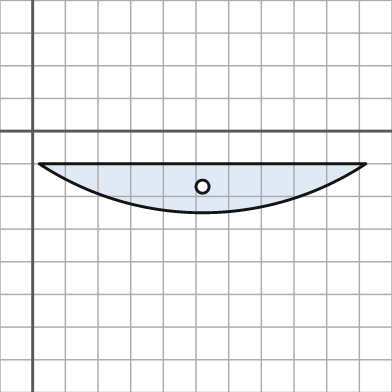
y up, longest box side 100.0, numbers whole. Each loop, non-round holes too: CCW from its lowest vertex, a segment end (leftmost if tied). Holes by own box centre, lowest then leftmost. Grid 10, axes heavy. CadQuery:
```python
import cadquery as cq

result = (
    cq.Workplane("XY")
    .moveTo(2.0, -10.0)
    .threePointArc((52.0, -25.0), (102.0, -10.0))
    .close()
    .moveTo(52.0, -17.0)
    .circle(2.0)
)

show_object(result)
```